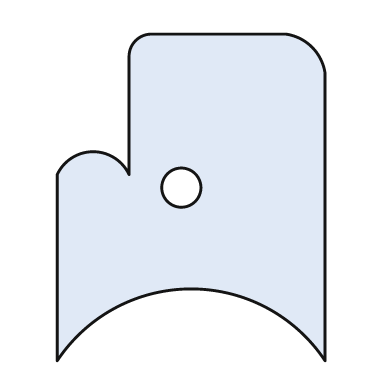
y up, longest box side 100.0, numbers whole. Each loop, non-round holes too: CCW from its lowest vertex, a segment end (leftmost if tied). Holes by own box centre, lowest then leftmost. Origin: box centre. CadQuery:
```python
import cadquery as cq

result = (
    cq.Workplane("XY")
    .moveTo(-41.0, -50.0)
    .threePointArc((0.0, -28.0), (41.0, -50.0))
    .lineTo(41.0, 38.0)
    .threePointArc((37.0, 46.0), (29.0, 50.0))
    .lineTo(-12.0, 50.0)
    .threePointArc((-17.0, 48.0), (-19.0, 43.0))
    .lineTo(-19.0, 7.0)
    .threePointArc((-30.0, 14.0), (-41.0, 7.0))
    .close()
    .moveTo(-3.0, 3.0)
    .circle(6.0)
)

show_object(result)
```